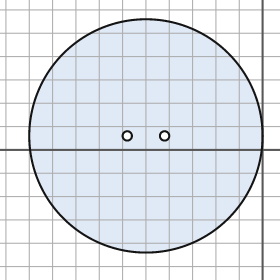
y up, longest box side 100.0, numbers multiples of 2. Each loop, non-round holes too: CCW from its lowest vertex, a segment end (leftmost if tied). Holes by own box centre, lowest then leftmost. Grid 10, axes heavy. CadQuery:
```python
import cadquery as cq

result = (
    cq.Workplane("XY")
    .moveTo(-50.0, 6.0)
    .circle(50.0)
    .moveTo(-58.0, 6.0)
    .circle(2.0)
    .moveTo(-42.0, 6.0)
    .circle(2.0)
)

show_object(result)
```